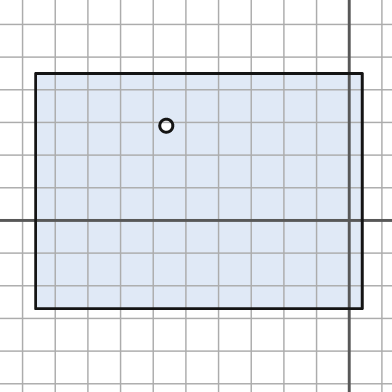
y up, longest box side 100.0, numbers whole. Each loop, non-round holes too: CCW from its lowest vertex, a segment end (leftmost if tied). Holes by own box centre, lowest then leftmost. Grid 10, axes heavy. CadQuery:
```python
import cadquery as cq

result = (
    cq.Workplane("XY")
    .moveTo(-96.0, -27.0)
    .lineTo(4.0, -27.0)
    .lineTo(4.0, 45.0)
    .lineTo(-96.0, 45.0)
    .close()
    .moveTo(-56.0, 29.0)
    .circle(2.0)
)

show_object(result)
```